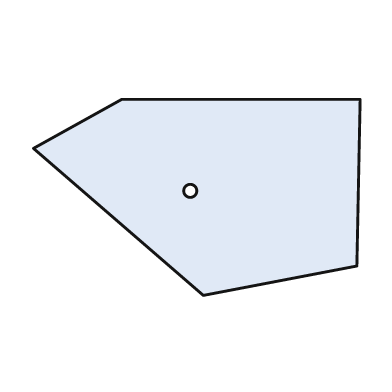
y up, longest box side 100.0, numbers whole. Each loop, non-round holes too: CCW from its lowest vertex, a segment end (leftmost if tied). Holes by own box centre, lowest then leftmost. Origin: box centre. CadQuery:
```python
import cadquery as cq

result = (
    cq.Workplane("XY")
    .moveTo(2.0, -30.0)
    .lineTo(49.0, -21.0)
    .lineTo(50.0, 30.0)
    .lineTo(-23.0, 30.0)
    .lineTo(-50.0, 15.0)
    .close()
    .moveTo(-2.0, 2.0)
    .circle(2.0)
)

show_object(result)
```